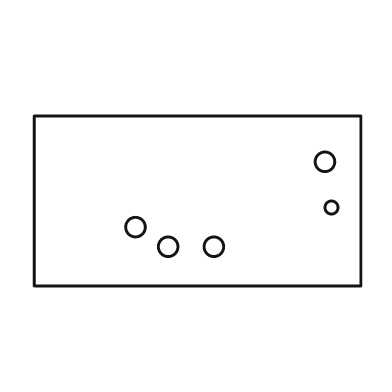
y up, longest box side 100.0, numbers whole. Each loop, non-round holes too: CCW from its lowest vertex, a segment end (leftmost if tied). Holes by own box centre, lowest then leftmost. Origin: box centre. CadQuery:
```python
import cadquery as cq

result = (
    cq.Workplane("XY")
    .moveTo(-50.0, -26.0)
    .lineTo(50.0, -26.0)
    .lineTo(50.0, 26.0)
    .lineTo(-50.0, 26.0)
    .close()
    .moveTo(-9.0, -14.0)
    .circle(3.0)
    .moveTo(5.0, -14.0)
    .circle(3.0)
    .moveTo(-19.0, -8.0)
    .circle(3.0)
    .moveTo(41.0, -2.0)
    .circle(2.0)
    .moveTo(39.0, 12.0)
    .circle(3.0)
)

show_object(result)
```